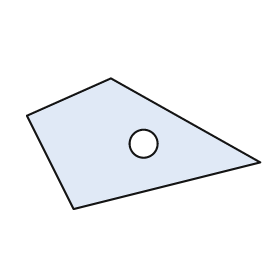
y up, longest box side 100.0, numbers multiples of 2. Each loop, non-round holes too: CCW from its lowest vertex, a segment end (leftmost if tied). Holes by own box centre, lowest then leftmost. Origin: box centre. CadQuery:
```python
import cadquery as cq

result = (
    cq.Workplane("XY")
    .moveTo(-30.0, -28.0)
    .lineTo(50.0, -8.0)
    .lineTo(-14.0, 28.0)
    .lineTo(-50.0, 12.0)
    .close()
    .moveTo(0.0, 0.0)
    .circle(6.0)
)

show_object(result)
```